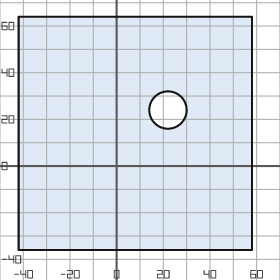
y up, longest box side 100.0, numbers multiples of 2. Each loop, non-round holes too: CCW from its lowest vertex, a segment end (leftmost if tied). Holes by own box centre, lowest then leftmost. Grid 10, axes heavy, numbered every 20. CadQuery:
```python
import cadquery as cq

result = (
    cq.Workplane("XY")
    .moveTo(-42.0, -36.0)
    .lineTo(58.0, -36.0)
    .lineTo(58.0, 64.0)
    .lineTo(-42.0, 64.0)
    .close()
    .moveTo(22.0, 24.0)
    .circle(8.0)
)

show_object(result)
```